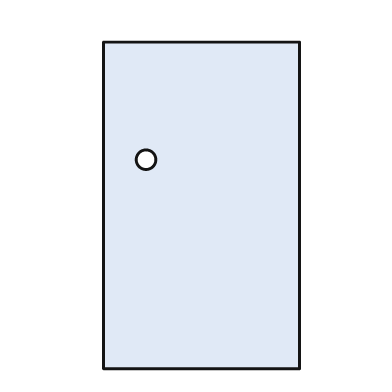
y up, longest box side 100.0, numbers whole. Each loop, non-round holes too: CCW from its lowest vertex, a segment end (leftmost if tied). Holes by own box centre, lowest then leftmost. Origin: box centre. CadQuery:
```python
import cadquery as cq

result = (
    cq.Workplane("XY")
    .moveTo(-30.0, -50.0)
    .lineTo(30.0, -50.0)
    .lineTo(30.0, 50.0)
    .lineTo(-30.0, 50.0)
    .close()
    .moveTo(-17.0, 14.0)
    .circle(3.0)
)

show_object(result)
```